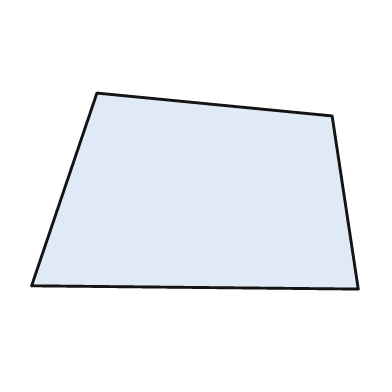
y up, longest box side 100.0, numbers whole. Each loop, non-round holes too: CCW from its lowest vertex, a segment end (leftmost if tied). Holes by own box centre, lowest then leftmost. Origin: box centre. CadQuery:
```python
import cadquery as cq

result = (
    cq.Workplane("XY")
    .moveTo(50.0, -30.0)
    .lineTo(42.0, 23.0)
    .lineTo(-30.0, 30.0)
    .lineTo(-50.0, -29.0)
    .close()
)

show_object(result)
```